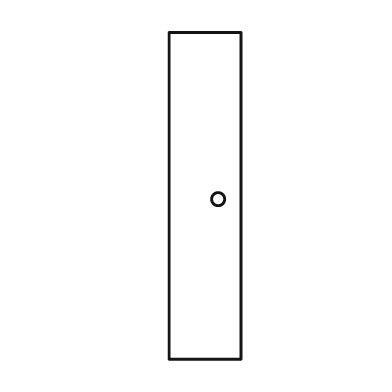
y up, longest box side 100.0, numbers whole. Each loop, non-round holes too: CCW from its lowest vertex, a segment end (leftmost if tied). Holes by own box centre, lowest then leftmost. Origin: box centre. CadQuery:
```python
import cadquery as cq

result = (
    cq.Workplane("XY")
    .moveTo(-11.0, -50.0)
    .lineTo(11.0, -50.0)
    .lineTo(11.0, 50.0)
    .lineTo(-11.0, 50.0)
    .close()
    .moveTo(4.0, -1.0)
    .circle(2.0)
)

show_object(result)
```